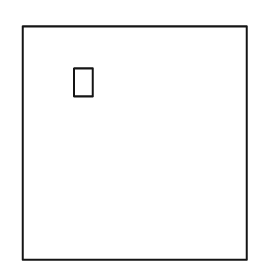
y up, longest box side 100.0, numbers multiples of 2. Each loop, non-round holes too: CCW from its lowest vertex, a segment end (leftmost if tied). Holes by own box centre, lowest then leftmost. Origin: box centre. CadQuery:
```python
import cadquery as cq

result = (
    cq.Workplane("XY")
    .moveTo(-48.0, -50.0)
    .lineTo(48.0, -50.0)
    .lineTo(48.0, 50.0)
    .lineTo(-48.0, 50.0)
    .close()
    .moveTo(-26.0, 20.0)
    .lineTo(-18.0, 20.0)
    .lineTo(-18.0, 32.0)
    .lineTo(-26.0, 32.0)
    .close()
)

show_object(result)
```